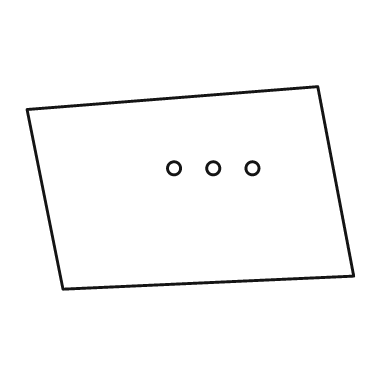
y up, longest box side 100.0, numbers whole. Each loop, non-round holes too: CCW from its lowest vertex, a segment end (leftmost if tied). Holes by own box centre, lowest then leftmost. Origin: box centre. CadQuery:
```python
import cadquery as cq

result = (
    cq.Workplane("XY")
    .moveTo(-39.0, -31.0)
    .lineTo(50.0, -27.0)
    .lineTo(39.0, 31.0)
    .lineTo(-50.0, 24.0)
    .close()
    .moveTo(-5.0, 6.0)
    .circle(2.0)
    .moveTo(7.0, 6.0)
    .circle(2.0)
    .moveTo(19.0, 6.0)
    .circle(2.0)
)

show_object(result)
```